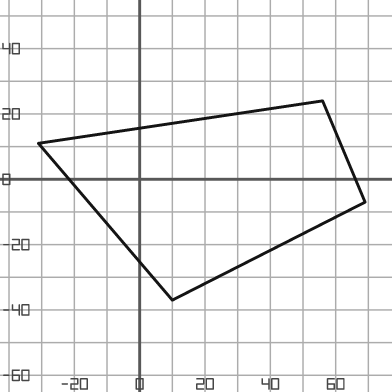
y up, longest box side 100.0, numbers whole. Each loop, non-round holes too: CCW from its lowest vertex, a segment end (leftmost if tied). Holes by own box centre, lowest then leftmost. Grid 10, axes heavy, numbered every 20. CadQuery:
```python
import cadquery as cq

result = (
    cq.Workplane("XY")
    .moveTo(10.0, -37.0)
    .lineTo(69.0, -7.0)
    .lineTo(56.0, 24.0)
    .lineTo(-31.0, 11.0)
    .close()
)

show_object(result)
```